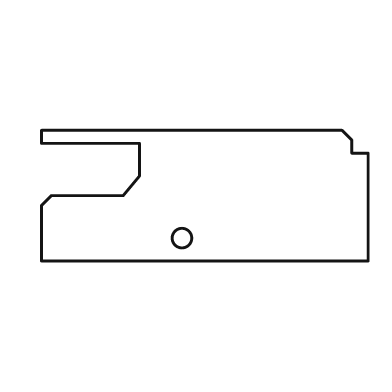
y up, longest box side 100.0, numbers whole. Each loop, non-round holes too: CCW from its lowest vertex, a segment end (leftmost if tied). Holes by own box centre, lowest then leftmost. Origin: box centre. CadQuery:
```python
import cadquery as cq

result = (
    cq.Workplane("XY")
    .moveTo(-50.0, -20.0)
    .lineTo(50.0, -20.0)
    .lineTo(50.0, 13.0)
    .lineTo(45.0, 13.0)
    .lineTo(45.0, 17.0)
    .lineTo(42.0, 20.0)
    .lineTo(-50.0, 20.0)
    .lineTo(-50.0, 16.0)
    .lineTo(-20.0, 16.0)
    .lineTo(-20.0, 6.0)
    .lineTo(-25.0, 0.0)
    .lineTo(-47.0, 0.0)
    .lineTo(-50.0, -3.0)
    .close()
    .moveTo(-7.0, -13.0)
    .circle(3.0)
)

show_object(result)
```